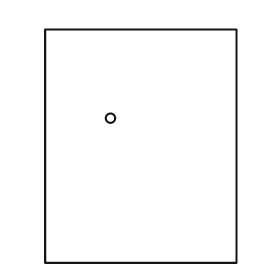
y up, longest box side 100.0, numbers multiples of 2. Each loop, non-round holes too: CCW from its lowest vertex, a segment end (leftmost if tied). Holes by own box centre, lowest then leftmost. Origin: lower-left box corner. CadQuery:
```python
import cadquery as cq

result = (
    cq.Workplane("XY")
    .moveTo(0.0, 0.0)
    .lineTo(82.0, 0.0)
    .lineTo(82.0, 100.0)
    .lineTo(0.0, 100.0)
    .close()
    .moveTo(28.0, 62.0)
    .circle(2.0)
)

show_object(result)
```